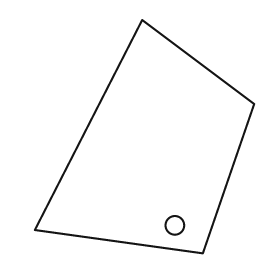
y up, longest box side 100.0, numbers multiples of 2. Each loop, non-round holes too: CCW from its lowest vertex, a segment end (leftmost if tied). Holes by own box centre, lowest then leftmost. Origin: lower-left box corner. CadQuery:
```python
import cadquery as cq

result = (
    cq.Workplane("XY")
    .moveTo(72.0, 0.0)
    .lineTo(94.0, 64.0)
    .lineTo(46.0, 100.0)
    .lineTo(0.0, 10.0)
    .close()
    .moveTo(60.0, 12.0)
    .circle(4.0)
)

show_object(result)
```